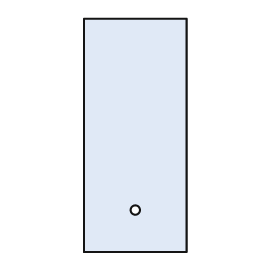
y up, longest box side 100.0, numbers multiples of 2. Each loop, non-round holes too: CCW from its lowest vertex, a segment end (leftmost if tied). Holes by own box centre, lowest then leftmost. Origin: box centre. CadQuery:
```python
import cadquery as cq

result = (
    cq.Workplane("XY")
    .moveTo(-22.0, -50.0)
    .lineTo(22.0, -50.0)
    .lineTo(22.0, 50.0)
    .lineTo(-22.0, 50.0)
    .close()
    .moveTo(0.0, -32.0)
    .circle(2.0)
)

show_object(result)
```